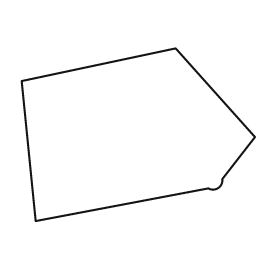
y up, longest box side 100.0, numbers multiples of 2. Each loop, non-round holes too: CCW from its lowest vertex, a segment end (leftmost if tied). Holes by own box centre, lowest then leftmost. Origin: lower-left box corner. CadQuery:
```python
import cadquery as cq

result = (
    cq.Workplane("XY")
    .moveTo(6.0, 0.0)
    .lineTo(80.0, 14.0)
    .threePointArc((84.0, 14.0), (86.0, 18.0))
    .lineTo(100.0, 36.0)
    .lineTo(66.0, 74.0)
    .lineTo(0.0, 60.0)
    .close()
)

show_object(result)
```